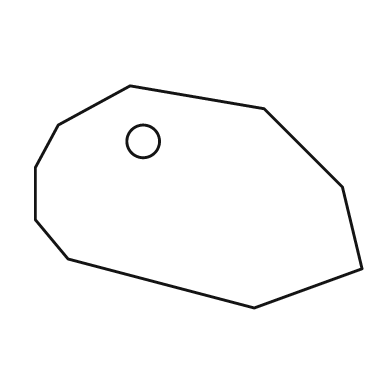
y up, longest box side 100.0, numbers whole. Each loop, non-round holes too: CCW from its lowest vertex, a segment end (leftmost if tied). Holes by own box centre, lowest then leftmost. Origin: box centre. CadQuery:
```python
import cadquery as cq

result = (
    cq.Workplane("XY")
    .moveTo(17.0, -34.0)
    .lineTo(50.0, -22.0)
    .lineTo(44.0, 3.0)
    .lineTo(20.0, 27.0)
    .lineTo(-21.0, 34.0)
    .lineTo(-43.0, 22.0)
    .lineTo(-50.0, 9.0)
    .lineTo(-50.0, -7.0)
    .lineTo(-40.0, -19.0)
    .close()
    .moveTo(-17.0, 17.0)
    .circle(5.0)
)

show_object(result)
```